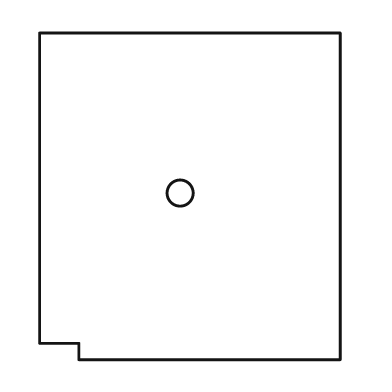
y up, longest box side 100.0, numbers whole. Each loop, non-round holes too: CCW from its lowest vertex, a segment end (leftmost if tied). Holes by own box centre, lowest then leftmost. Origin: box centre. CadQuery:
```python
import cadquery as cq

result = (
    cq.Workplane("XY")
    .moveTo(-34.0, -50.0)
    .lineTo(46.0, -50.0)
    .lineTo(46.0, 50.0)
    .lineTo(-46.0, 50.0)
    .lineTo(-46.0, -45.0)
    .lineTo(-34.0, -45.0)
    .close()
    .moveTo(-3.0, 1.0)
    .circle(4.0)
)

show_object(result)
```